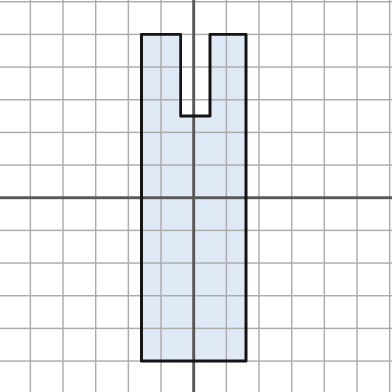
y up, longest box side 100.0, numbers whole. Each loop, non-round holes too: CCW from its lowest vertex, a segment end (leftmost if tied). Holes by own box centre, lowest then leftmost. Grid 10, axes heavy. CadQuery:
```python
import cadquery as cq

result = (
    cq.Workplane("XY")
    .moveTo(-16.0, -50.0)
    .lineTo(16.0, -50.0)
    .lineTo(16.0, 50.0)
    .lineTo(5.0, 50.0)
    .lineTo(5.0, 25.0)
    .lineTo(-4.0, 25.0)
    .lineTo(-4.0, 50.0)
    .lineTo(-16.0, 50.0)
    .close()
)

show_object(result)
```